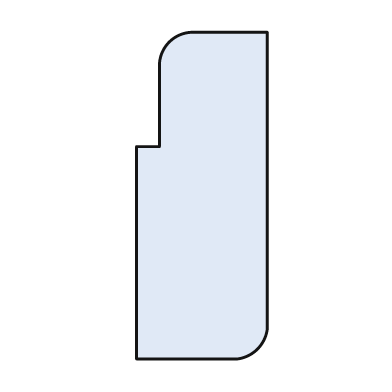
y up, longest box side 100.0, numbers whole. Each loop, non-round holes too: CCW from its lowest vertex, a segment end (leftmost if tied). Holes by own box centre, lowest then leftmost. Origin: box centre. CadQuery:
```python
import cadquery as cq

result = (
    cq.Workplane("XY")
    .moveTo(-20.0, -50.0)
    .lineTo(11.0, -50.0)
    .threePointArc((17.0, -47.0), (20.0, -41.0))
    .lineTo(20.0, 50.0)
    .lineTo(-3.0, 50.0)
    .threePointArc((-10.0, 47.0), (-13.0, 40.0))
    .lineTo(-13.0, 15.0)
    .lineTo(-20.0, 15.0)
    .close()
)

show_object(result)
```